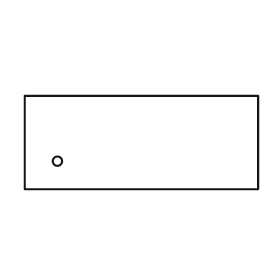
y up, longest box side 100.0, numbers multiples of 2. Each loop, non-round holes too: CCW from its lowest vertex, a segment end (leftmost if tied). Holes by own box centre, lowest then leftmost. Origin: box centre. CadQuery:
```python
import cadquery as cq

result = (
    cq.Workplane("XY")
    .moveTo(-50.0, -20.0)
    .lineTo(50.0, -20.0)
    .lineTo(50.0, 20.0)
    .lineTo(-50.0, 20.0)
    .close()
    .moveTo(-36.0, -8.0)
    .circle(2.0)
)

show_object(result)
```